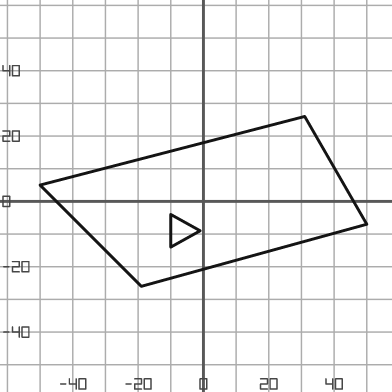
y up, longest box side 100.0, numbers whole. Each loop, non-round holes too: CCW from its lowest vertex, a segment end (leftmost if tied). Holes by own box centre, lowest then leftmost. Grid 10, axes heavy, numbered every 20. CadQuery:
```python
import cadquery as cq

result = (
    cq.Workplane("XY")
    .moveTo(-19.0, -26.0)
    .lineTo(50.0, -7.0)
    .lineTo(31.0, 26.0)
    .lineTo(-50.0, 5.0)
    .close()
    .moveTo(-10.0, -14.0)
    .lineTo(-1.0, -9.0)
    .lineTo(-10.0, -4.0)
    .close()
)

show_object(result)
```